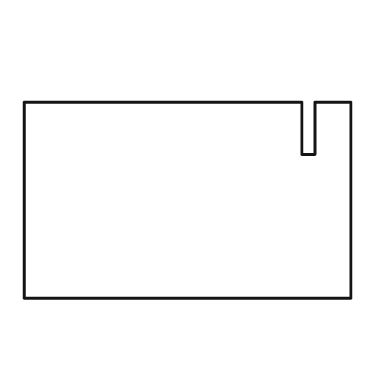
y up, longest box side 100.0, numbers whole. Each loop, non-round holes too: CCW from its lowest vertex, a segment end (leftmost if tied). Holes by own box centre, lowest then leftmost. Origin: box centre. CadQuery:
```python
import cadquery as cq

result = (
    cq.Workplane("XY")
    .moveTo(-50.0, -30.0)
    .lineTo(50.0, -30.0)
    .lineTo(50.0, 30.0)
    .lineTo(39.0, 30.0)
    .lineTo(39.0, 14.0)
    .lineTo(35.0, 14.0)
    .lineTo(35.0, 30.0)
    .lineTo(-50.0, 30.0)
    .close()
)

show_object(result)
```